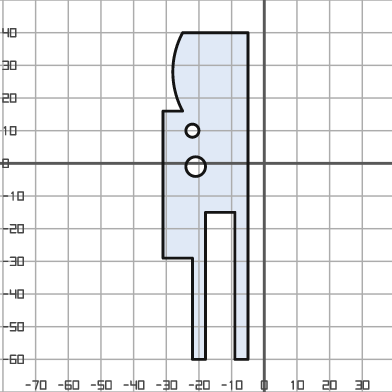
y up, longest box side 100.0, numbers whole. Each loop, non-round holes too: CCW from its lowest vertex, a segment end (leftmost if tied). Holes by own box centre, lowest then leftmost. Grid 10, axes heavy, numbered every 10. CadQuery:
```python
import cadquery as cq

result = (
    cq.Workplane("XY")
    .moveTo(-22.0, -60.0)
    .lineTo(-18.0, -60.0)
    .lineTo(-18.0, -15.0)
    .lineTo(-9.0, -15.0)
    .lineTo(-9.0, -60.0)
    .lineTo(-5.0, -60.0)
    .lineTo(-5.0, 40.0)
    .lineTo(-25.0, 40.0)
    .threePointArc((-28.0, 28.0), (-25.0, 16.0))
    .lineTo(-31.0, 16.0)
    .lineTo(-31.0, -29.0)
    .lineTo(-22.0, -29.0)
    .close()
    .moveTo(-21.0, -1.0)
    .circle(3.0)
    .moveTo(-22.0, 10.0)
    .circle(2.0)
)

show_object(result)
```